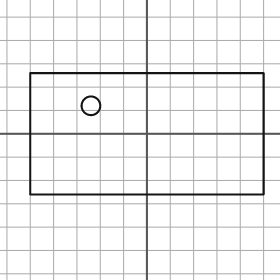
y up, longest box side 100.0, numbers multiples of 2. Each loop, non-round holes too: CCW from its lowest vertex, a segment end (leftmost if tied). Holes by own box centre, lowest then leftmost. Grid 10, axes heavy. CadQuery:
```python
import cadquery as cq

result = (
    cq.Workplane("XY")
    .moveTo(-50.0, -26.0)
    .lineTo(50.0, -26.0)
    .lineTo(50.0, 26.0)
    .lineTo(-50.0, 26.0)
    .close()
    .moveTo(-24.0, 12.0)
    .circle(4.0)
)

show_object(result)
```